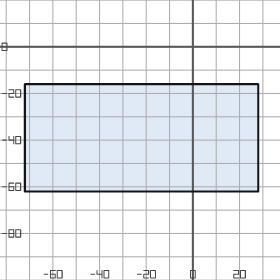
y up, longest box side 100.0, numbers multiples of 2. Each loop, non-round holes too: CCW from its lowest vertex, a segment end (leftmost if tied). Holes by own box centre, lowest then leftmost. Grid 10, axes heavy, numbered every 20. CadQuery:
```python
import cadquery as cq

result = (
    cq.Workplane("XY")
    .moveTo(-72.0, -62.0)
    .lineTo(28.0, -62.0)
    .lineTo(28.0, -16.0)
    .lineTo(-72.0, -16.0)
    .close()
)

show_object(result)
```